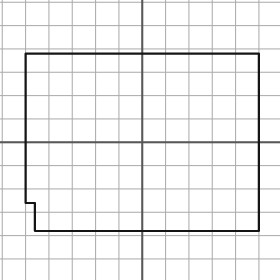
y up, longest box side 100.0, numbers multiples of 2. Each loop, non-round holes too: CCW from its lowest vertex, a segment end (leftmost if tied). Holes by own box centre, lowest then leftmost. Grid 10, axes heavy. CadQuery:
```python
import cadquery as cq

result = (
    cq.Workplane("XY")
    .moveTo(-46.0, -38.0)
    .lineTo(50.0, -38.0)
    .lineTo(50.0, 38.0)
    .lineTo(-50.0, 38.0)
    .lineTo(-50.0, -26.0)
    .lineTo(-46.0, -26.0)
    .close()
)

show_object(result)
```